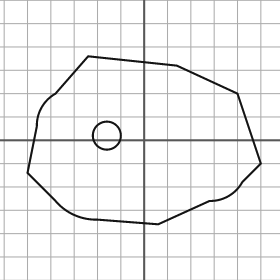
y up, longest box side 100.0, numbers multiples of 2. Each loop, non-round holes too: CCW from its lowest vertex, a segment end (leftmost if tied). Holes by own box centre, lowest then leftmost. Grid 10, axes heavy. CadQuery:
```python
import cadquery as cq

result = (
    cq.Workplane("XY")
    .moveTo(6.0, -36.0)
    .lineTo(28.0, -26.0)
    .threePointArc((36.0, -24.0), (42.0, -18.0))
    .lineTo(50.0, -10.0)
    .lineTo(40.0, 20.0)
    .lineTo(14.0, 32.0)
    .lineTo(-24.0, 36.0)
    .lineTo(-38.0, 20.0)
    .threePointArc((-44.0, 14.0), (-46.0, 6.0))
    .lineTo(-50.0, -14.0)
    .lineTo(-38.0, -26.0)
    .threePointArc((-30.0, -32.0), (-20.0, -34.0))
    .close()
    .moveTo(-16.0, 2.0)
    .circle(6.0)
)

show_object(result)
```